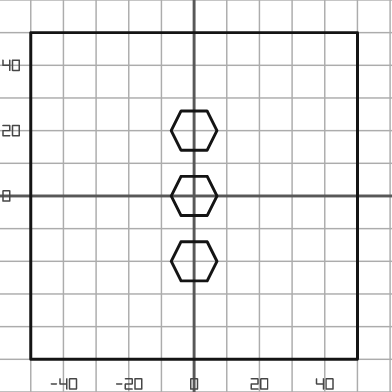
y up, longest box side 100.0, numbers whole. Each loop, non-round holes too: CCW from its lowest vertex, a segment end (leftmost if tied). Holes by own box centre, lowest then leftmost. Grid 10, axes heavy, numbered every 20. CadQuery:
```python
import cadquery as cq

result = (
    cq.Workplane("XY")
    .moveTo(-50.0, -50.0)
    .lineTo(50.0, -50.0)
    .lineTo(50.0, 50.0)
    .lineTo(-50.0, 50.0)
    .close()
    .moveTo(-4.0, -26.0)
    .lineTo(4.0, -26.0)
    .lineTo(7.0, -20.0)
    .lineTo(4.0, -14.0)
    .lineTo(-4.0, -14.0)
    .lineTo(-7.0, -20.0)
    .close()
    .moveTo(-4.0, -6.0)
    .lineTo(4.0, -6.0)
    .lineTo(7.0, 0.0)
    .lineTo(4.0, 6.0)
    .lineTo(-4.0, 6.0)
    .lineTo(-7.0, 0.0)
    .close()
    .moveTo(-4.0, 14.0)
    .lineTo(4.0, 14.0)
    .lineTo(7.0, 20.0)
    .lineTo(4.0, 26.0)
    .lineTo(-4.0, 26.0)
    .lineTo(-7.0, 20.0)
    .close()
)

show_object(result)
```